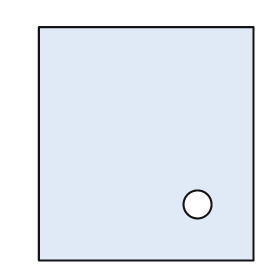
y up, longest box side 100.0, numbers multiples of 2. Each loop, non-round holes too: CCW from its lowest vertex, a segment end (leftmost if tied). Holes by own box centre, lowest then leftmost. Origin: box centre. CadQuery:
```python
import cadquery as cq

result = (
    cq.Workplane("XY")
    .moveTo(-46.0, -50.0)
    .lineTo(46.0, -50.0)
    .lineTo(46.0, 50.0)
    .lineTo(-46.0, 50.0)
    .close()
    .moveTo(22.0, -26.0)
    .circle(6.0)
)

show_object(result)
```